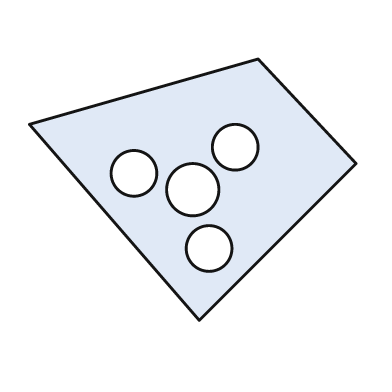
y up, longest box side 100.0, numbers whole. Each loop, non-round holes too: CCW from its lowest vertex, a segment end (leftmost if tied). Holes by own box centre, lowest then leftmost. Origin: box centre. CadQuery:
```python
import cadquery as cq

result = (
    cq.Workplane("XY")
    .moveTo(2.0, -40.0)
    .lineTo(50.0, 8.0)
    .lineTo(20.0, 40.0)
    .lineTo(-50.0, 20.0)
    .close()
    .moveTo(5.0, -18.0)
    .circle(7.0)
    .moveTo(0.0, 0.0)
    .circle(8.0)
    .moveTo(-18.0, 5.0)
    .circle(7.0)
    .moveTo(13.0, 13.0)
    .circle(7.0)
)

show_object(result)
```